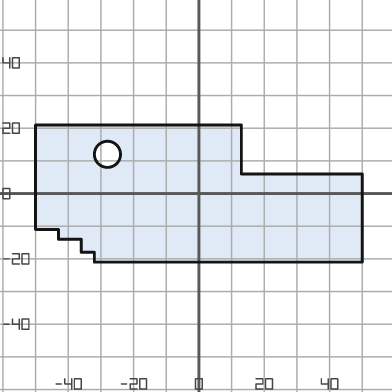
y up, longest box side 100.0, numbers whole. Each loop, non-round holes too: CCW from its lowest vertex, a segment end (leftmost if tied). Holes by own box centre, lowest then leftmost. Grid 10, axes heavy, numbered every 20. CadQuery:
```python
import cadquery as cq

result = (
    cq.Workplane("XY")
    .moveTo(-32.0, -21.0)
    .lineTo(50.0, -21.0)
    .lineTo(50.0, 6.0)
    .lineTo(13.0, 6.0)
    .lineTo(13.0, 21.0)
    .lineTo(-50.0, 21.0)
    .lineTo(-50.0, -11.0)
    .lineTo(-43.0, -11.0)
    .lineTo(-43.0, -14.0)
    .lineTo(-36.0, -14.0)
    .lineTo(-36.0, -18.0)
    .lineTo(-32.0, -18.0)
    .close()
    .moveTo(-28.0, 12.0)
    .circle(4.0)
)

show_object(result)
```